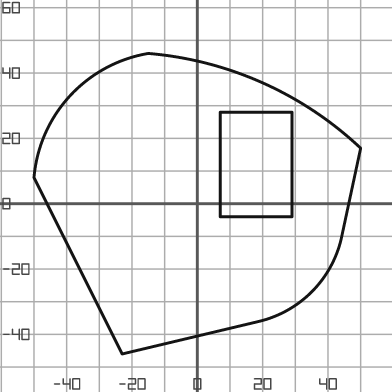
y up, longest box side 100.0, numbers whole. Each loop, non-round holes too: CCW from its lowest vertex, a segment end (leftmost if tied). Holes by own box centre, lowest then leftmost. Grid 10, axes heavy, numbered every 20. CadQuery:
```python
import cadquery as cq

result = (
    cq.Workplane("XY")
    .moveTo(-23.0, -46.0)
    .lineTo(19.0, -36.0)
    .threePointArc((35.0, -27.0), (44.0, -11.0))
    .lineTo(50.0, 17.0)
    .threePointArc((20.0, 37.0), (-15.0, 46.0))
    .threePointArc((-39.0, 33.0), (-50.0, 8.0))
    .close()
    .moveTo(7.0, -4.0)
    .lineTo(29.0, -4.0)
    .lineTo(29.0, 28.0)
    .lineTo(7.0, 28.0)
    .close()
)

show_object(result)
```